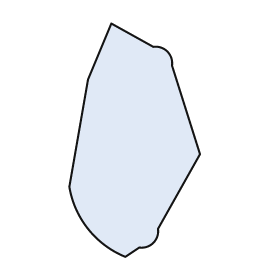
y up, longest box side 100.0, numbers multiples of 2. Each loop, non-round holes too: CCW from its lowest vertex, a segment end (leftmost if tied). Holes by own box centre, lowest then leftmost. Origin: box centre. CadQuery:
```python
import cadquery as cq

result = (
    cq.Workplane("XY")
    .moveTo(-4.0, -50.0)
    .lineTo(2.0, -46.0)
    .threePointArc((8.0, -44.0), (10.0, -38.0))
    .lineTo(28.0, -6.0)
    .lineTo(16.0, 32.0)
    .threePointArc((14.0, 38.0), (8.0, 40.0))
    .lineTo(-10.0, 50.0)
    .lineTo(-20.0, 26.0)
    .lineTo(-28.0, -20.0)
    .threePointArc((-20.0, -38.0), (-4.0, -50.0))
    .close()
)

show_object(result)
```